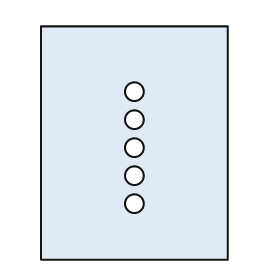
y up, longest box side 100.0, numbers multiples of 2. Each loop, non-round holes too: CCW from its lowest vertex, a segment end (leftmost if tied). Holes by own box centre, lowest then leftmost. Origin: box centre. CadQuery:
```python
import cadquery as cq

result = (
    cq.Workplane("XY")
    .moveTo(-40.0, -50.0)
    .lineTo(40.0, -50.0)
    .lineTo(40.0, 50.0)
    .lineTo(-40.0, 50.0)
    .close()
    .moveTo(0.0, -26.0)
    .circle(4.0)
    .moveTo(0.0, -14.0)
    .circle(4.0)
    .moveTo(0.0, -2.0)
    .circle(4.0)
    .moveTo(0.0, 10.0)
    .circle(4.0)
    .moveTo(0.0, 22.0)
    .circle(4.0)
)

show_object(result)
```